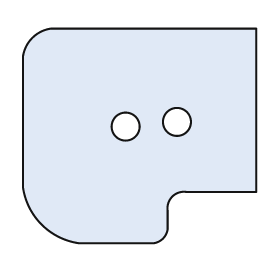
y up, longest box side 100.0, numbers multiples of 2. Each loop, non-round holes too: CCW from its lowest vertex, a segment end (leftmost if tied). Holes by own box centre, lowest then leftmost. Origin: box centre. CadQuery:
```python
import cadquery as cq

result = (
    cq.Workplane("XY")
    .moveTo(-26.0, -46.0)
    .lineTo(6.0, -46.0)
    .threePointArc((10.0, -44.0), (12.0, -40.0))
    .lineTo(12.0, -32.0)
    .threePointArc((14.0, -26.0), (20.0, -24.0))
    .lineTo(50.0, -24.0)
    .lineTo(50.0, 46.0)
    .lineTo(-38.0, 46.0)
    .threePointArc((-46.0, 42.0), (-50.0, 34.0))
    .lineTo(-50.0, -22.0)
    .threePointArc((-42.0, -38.0), (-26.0, -46.0))
    .close()
    .moveTo(-6.0, 4.0)
    .circle(6.0)
    .moveTo(16.0, 6.0)
    .circle(6.0)
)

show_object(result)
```